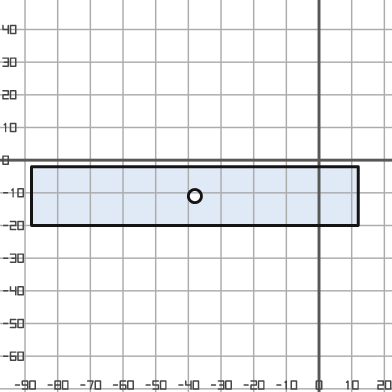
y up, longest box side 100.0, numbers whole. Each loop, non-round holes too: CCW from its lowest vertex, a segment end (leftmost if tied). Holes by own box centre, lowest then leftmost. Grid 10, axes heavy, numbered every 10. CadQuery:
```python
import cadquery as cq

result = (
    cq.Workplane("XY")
    .moveTo(-88.0, -20.0)
    .lineTo(12.0, -20.0)
    .lineTo(12.0, -2.0)
    .lineTo(-88.0, -2.0)
    .close()
    .moveTo(-38.0, -11.0)
    .circle(2.0)
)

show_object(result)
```